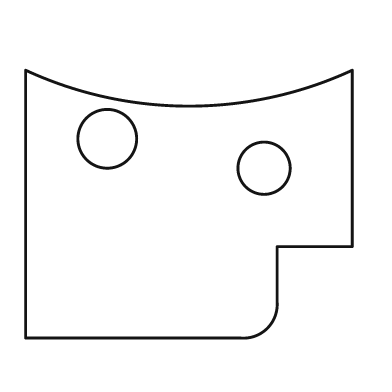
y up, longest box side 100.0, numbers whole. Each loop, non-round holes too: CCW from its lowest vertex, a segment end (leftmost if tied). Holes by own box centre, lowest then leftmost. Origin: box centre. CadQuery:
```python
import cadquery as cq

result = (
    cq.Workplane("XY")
    .moveTo(-50.0, -41.0)
    .lineTo(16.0, -41.0)
    .threePointArc((24.0, -38.0), (27.0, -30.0))
    .lineTo(27.0, -13.0)
    .lineTo(50.0, -13.0)
    .lineTo(50.0, 41.0)
    .threePointArc((0.0, 30.0), (-50.0, 41.0))
    .close()
    .moveTo(23.0, 11.0)
    .circle(8.0)
    .moveTo(-25.0, 20.0)
    .circle(9.0)
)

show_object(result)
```